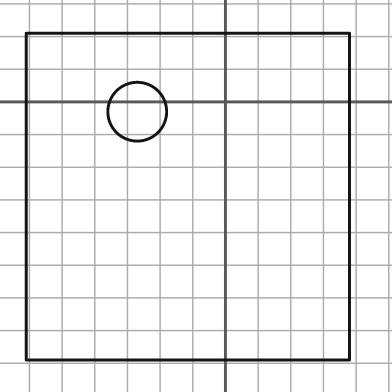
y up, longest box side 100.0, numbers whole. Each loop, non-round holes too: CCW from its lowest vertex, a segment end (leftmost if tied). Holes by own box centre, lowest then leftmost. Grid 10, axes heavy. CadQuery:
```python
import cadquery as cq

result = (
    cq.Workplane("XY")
    .moveTo(-61.0, -79.0)
    .lineTo(38.0, -79.0)
    .lineTo(38.0, 21.0)
    .lineTo(-61.0, 21.0)
    .close()
    .moveTo(-27.0, -3.0)
    .circle(9.0)
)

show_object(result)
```